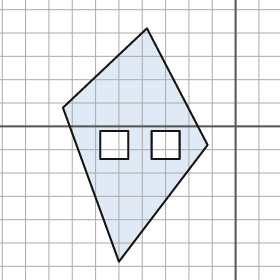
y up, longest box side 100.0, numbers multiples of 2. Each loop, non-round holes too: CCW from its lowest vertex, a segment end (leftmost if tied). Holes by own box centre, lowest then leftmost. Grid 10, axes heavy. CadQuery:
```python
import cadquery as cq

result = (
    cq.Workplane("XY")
    .moveTo(-50.0, -58.0)
    .lineTo(-12.0, -8.0)
    .lineTo(-38.0, 42.0)
    .lineTo(-74.0, 8.0)
    .close()
    .moveTo(-58.0, -14.0)
    .lineTo(-46.0, -14.0)
    .lineTo(-46.0, -2.0)
    .lineTo(-58.0, -2.0)
    .close()
    .moveTo(-36.0, -14.0)
    .lineTo(-24.0, -14.0)
    .lineTo(-24.0, -2.0)
    .lineTo(-36.0, -2.0)
    .close()
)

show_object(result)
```